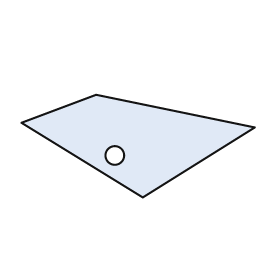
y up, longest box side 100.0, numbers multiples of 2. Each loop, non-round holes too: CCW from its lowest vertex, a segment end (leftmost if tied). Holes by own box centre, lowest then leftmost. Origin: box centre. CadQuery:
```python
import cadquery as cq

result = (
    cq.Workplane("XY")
    .moveTo(2.0, -22.0)
    .lineTo(50.0, 8.0)
    .lineTo(-18.0, 22.0)
    .lineTo(-50.0, 10.0)
    .close()
    .moveTo(-10.0, -4.0)
    .circle(4.0)
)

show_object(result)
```